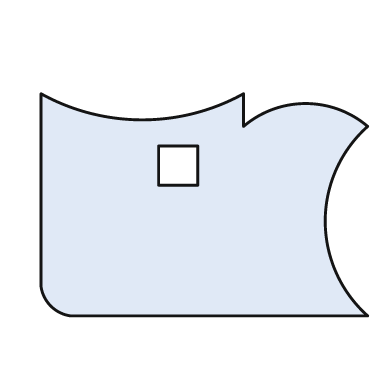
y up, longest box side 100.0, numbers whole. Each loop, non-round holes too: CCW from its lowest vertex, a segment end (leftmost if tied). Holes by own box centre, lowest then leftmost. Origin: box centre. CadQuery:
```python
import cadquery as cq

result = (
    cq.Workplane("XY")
    .moveTo(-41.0, -34.0)
    .lineTo(50.0, -34.0)
    .threePointArc((37.0, -5.0), (50.0, 24.0))
    .threePointArc((31.0, 31.0), (12.0, 24.0))
    .lineTo(12.0, 34.0)
    .threePointArc((-19.0, 26.0), (-50.0, 34.0))
    .lineTo(-50.0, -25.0)
    .threePointArc((-47.0, -31.0), (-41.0, -34.0))
    .close()
    .moveTo(-14.0, 6.0)
    .lineTo(-2.0, 6.0)
    .lineTo(-2.0, 18.0)
    .lineTo(-14.0, 18.0)
    .close()
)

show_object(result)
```